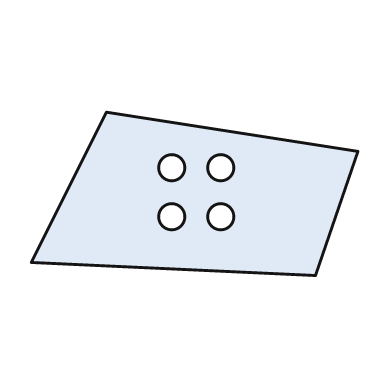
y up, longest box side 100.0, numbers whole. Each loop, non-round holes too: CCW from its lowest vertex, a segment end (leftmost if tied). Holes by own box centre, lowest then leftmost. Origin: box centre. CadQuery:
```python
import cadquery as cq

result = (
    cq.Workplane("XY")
    .moveTo(37.0, -25.0)
    .lineTo(50.0, 13.0)
    .lineTo(-27.0, 25.0)
    .lineTo(-50.0, -21.0)
    .close()
    .moveTo(-7.0, -7.0)
    .circle(4.0)
    .moveTo(8.0, -7.0)
    .circle(4.0)
    .moveTo(-7.0, 8.0)
    .circle(4.0)
    .moveTo(8.0, 8.0)
    .circle(4.0)
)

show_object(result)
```